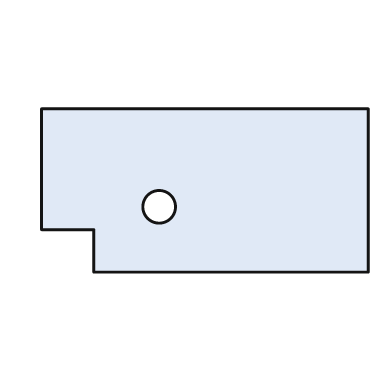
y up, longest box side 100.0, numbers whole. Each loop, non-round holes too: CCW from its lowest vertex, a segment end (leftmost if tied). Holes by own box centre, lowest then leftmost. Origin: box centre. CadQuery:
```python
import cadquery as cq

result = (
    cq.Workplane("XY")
    .moveTo(-34.0, -25.0)
    .lineTo(50.0, -25.0)
    .lineTo(50.0, 25.0)
    .lineTo(-50.0, 25.0)
    .lineTo(-50.0, -12.0)
    .lineTo(-34.0, -12.0)
    .close()
    .moveTo(-14.0, -5.0)
    .circle(5.0)
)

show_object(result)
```